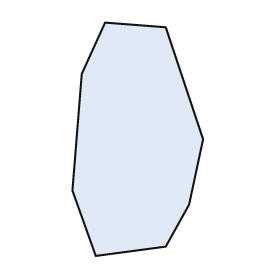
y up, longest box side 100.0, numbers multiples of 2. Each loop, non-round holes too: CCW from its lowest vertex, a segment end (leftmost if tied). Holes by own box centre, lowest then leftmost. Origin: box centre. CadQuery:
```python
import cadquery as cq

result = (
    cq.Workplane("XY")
    .moveTo(-18.0, -50.0)
    .lineTo(12.0, -46.0)
    .lineTo(22.0, -28.0)
    .lineTo(28.0, 0.0)
    .lineTo(12.0, 48.0)
    .lineTo(-14.0, 50.0)
    .lineTo(-24.0, 28.0)
    .lineTo(-28.0, -22.0)
    .close()
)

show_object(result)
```